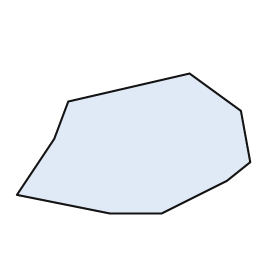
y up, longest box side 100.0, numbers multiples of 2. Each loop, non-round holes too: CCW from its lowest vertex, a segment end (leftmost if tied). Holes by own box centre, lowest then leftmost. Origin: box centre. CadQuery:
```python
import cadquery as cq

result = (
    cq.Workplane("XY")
    .moveTo(-10.0, -30.0)
    .lineTo(12.0, -30.0)
    .lineTo(40.0, -16.0)
    .lineTo(50.0, -8.0)
    .lineTo(46.0, 14.0)
    .lineTo(24.0, 30.0)
    .lineTo(-28.0, 18.0)
    .lineTo(-34.0, 2.0)
    .lineTo(-50.0, -22.0)
    .close()
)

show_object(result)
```